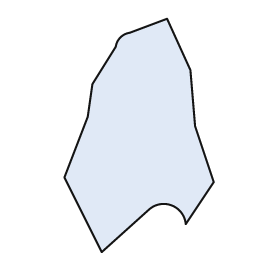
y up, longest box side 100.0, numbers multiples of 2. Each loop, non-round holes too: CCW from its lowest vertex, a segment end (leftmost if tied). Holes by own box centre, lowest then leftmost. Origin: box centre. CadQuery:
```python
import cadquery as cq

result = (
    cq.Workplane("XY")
    .moveTo(-16.0, -50.0)
    .lineTo(4.0, -32.0)
    .threePointArc((14.0, -30.0), (20.0, -38.0))
    .lineTo(32.0, -20.0)
    .lineTo(24.0, 4.0)
    .lineTo(22.0, 28.0)
    .lineTo(12.0, 50.0)
    .lineTo(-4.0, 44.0)
    .threePointArc((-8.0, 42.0), (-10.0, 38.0))
    .lineTo(-20.0, 22.0)
    .lineTo(-22.0, 8.0)
    .lineTo(-32.0, -18.0)
    .close()
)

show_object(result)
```